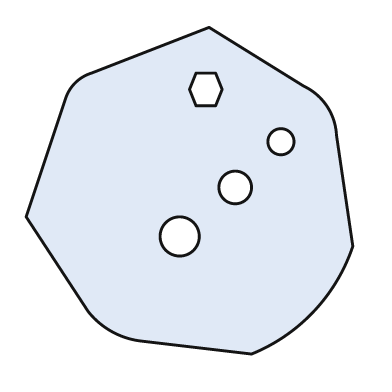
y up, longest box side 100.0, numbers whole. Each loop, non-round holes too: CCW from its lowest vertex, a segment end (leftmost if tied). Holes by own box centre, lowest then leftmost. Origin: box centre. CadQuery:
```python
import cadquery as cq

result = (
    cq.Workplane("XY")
    .moveTo(19.0, -50.0)
    .threePointArc((38.0, -37.0), (50.0, -17.0))
    .lineTo(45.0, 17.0)
    .threePointArc((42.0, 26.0), (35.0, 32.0))
    .lineTo(6.0, 50.0)
    .lineTo(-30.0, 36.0)
    .threePointArc((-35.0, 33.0), (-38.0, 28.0))
    .lineTo(-50.0, -8.0)
    .lineTo(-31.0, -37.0)
    .threePointArc((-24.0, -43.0), (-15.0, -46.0))
    .close()
    .moveTo(-3.0, -14.0)
    .circle(6.0)
    .moveTo(14.0, 1.0)
    .circle(5.0)
    .moveTo(28.0, 15.0)
    .circle(4.0)
    .moveTo(2.0, 26.0)
    .lineTo(8.0, 26.0)
    .lineTo(10.0, 31.0)
    .lineTo(8.0, 36.0)
    .lineTo(2.0, 36.0)
    .lineTo(0.0, 31.0)
    .close()
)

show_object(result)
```